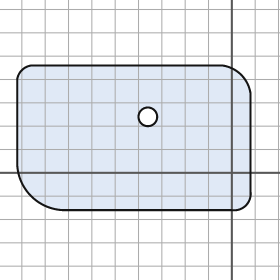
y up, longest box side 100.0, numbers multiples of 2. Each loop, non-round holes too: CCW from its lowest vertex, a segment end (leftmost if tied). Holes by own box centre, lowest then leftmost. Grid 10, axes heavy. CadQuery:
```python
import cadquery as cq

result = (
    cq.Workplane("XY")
    .moveTo(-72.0, -16.0)
    .lineTo(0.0, -16.0)
    .threePointArc((6.0, -14.0), (8.0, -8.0))
    .lineTo(8.0, 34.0)
    .threePointArc((4.0, 42.0), (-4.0, 46.0))
    .lineTo(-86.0, 46.0)
    .threePointArc((-90.0, 44.0), (-92.0, 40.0))
    .lineTo(-92.0, 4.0)
    .threePointArc((-86.0, -10.0), (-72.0, -16.0))
    .close()
    .moveTo(-36.0, 24.0)
    .circle(4.0)
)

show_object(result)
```